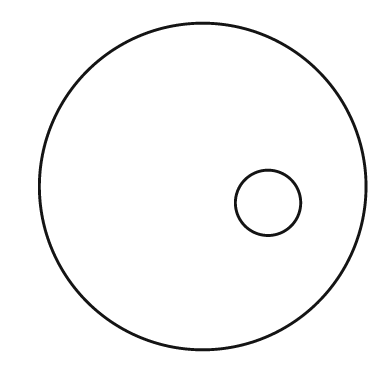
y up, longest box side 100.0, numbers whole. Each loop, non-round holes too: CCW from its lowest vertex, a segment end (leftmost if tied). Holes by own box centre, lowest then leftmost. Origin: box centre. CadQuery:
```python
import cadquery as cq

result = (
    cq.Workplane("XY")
    .moveTo(0.0, 0.0)
    .circle(50.0)
    .moveTo(20.0, -5.0)
    .circle(10.0)
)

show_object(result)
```